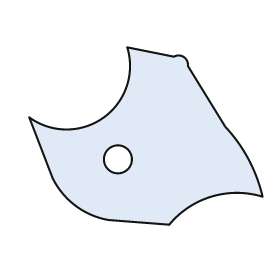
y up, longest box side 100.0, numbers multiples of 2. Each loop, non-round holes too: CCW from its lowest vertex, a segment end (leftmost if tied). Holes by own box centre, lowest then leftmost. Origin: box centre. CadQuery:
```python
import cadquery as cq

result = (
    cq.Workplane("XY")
    .moveTo(10.0, -38.0)
    .threePointArc((28.0, -26.0), (50.0, -26.0))
    .threePointArc((44.0, -10.0), (34.0, 4.0))
    .lineTo(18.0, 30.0)
    .threePointArc((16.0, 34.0), (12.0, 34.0))
    .lineTo(-8.0, 38.0)
    .threePointArc((-18.0, 8.0), (-50.0, 8.0))
    .lineTo(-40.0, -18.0)
    .threePointArc((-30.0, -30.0), (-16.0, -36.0))
    .close()
    .moveTo(-12.0, -10.0)
    .circle(6.0)
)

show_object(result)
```